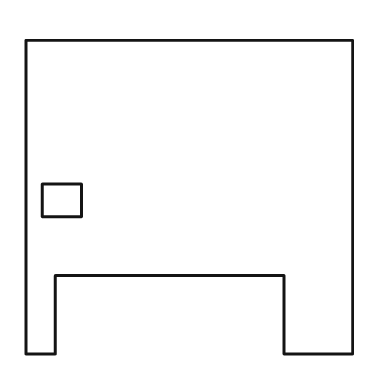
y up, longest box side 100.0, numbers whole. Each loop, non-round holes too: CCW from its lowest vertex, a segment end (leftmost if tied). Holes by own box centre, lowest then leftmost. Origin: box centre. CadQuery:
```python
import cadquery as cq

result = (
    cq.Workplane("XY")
    .moveTo(-50.0, -48.0)
    .lineTo(-41.0, -48.0)
    .lineTo(-41.0, -24.0)
    .lineTo(29.0, -24.0)
    .lineTo(29.0, -48.0)
    .lineTo(50.0, -48.0)
    .lineTo(50.0, 48.0)
    .lineTo(-50.0, 48.0)
    .close()
    .moveTo(-45.0, -6.0)
    .lineTo(-33.0, -6.0)
    .lineTo(-33.0, 4.0)
    .lineTo(-45.0, 4.0)
    .close()
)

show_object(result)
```